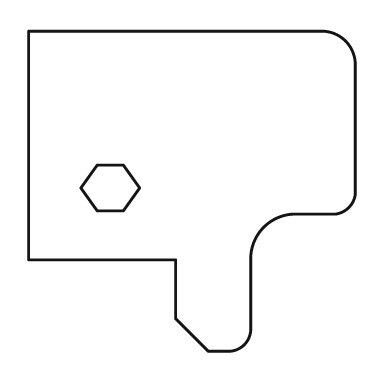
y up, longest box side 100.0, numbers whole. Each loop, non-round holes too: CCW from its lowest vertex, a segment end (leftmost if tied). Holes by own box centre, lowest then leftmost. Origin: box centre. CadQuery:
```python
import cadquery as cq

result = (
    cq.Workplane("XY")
    .moveTo(5.0, -49.0)
    .lineTo(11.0, -49.0)
    .threePointArc((16.0, -47.0), (18.0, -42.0))
    .lineTo(18.0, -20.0)
    .threePointArc((22.0, -11.0), (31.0, -7.0))
    .lineTo(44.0, -7.0)
    .threePointArc((48.0, -5.0), (50.0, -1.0))
    .lineTo(50.0, 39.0)
    .threePointArc((47.0, 46.0), (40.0, 49.0))
    .lineTo(-50.0, 49.0)
    .lineTo(-50.0, -21.0)
    .lineTo(-5.0, -21.0)
    .lineTo(-5.0, -39.0)
    .close()
    .moveTo(-29.0, -6.0)
    .lineTo(-21.0, -6.0)
    .lineTo(-16.0, 1.0)
    .lineTo(-21.0, 8.0)
    .lineTo(-29.0, 8.0)
    .lineTo(-34.0, 1.0)
    .close()
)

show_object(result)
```